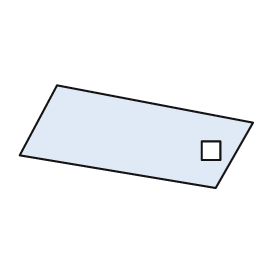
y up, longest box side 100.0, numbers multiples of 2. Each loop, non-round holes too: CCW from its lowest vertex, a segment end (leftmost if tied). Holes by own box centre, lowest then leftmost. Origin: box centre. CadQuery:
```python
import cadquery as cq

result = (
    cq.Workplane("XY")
    .moveTo(34.0, -22.0)
    .lineTo(50.0, 6.0)
    .lineTo(-34.0, 22.0)
    .lineTo(-50.0, -8.0)
    .close()
    .moveTo(28.0, -10.0)
    .lineTo(36.0, -10.0)
    .lineTo(36.0, -2.0)
    .lineTo(28.0, -2.0)
    .close()
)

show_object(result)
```